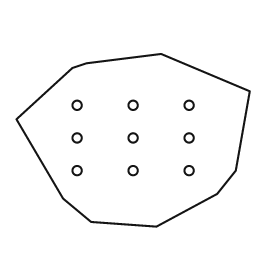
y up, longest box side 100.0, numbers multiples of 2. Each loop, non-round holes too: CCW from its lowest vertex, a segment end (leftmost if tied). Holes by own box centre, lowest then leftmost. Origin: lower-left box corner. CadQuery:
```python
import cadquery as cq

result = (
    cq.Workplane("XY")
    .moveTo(60.0, 0.0)
    .lineTo(86.0, 14.0)
    .lineTo(94.0, 24.0)
    .lineTo(100.0, 58.0)
    .lineTo(62.0, 74.0)
    .lineTo(30.0, 70.0)
    .lineTo(24.0, 68.0)
    .lineTo(0.0, 46.0)
    .lineTo(20.0, 12.0)
    .lineTo(32.0, 2.0)
    .close()
    .moveTo(26.0, 24.0)
    .circle(2.0)
    .moveTo(50.0, 24.0)
    .circle(2.0)
    .moveTo(74.0, 24.0)
    .circle(2.0)
    .moveTo(26.0, 38.0)
    .circle(2.0)
    .moveTo(50.0, 38.0)
    .circle(2.0)
    .moveTo(74.0, 38.0)
    .circle(2.0)
    .moveTo(26.0, 52.0)
    .circle(2.0)
    .moveTo(50.0, 52.0)
    .circle(2.0)
    .moveTo(74.0, 52.0)
    .circle(2.0)
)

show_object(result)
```